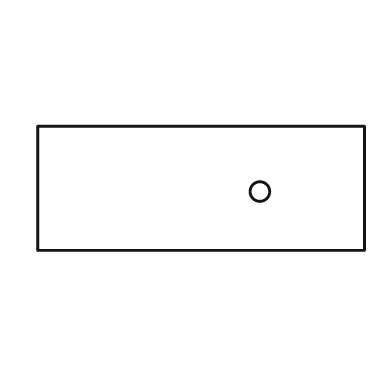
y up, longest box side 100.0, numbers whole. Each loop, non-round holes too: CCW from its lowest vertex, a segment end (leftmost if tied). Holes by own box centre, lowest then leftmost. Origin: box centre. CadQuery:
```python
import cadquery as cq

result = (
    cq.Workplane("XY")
    .moveTo(-50.0, -19.0)
    .lineTo(50.0, -19.0)
    .lineTo(50.0, 19.0)
    .lineTo(-50.0, 19.0)
    .close()
    .moveTo(18.0, -1.0)
    .circle(3.0)
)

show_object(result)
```